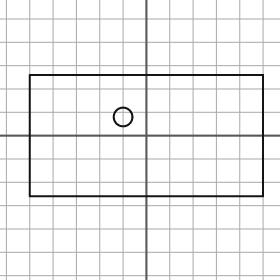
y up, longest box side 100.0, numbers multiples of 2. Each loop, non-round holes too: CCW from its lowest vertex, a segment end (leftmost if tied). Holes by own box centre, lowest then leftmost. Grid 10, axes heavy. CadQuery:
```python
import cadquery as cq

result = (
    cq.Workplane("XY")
    .moveTo(-50.0, -26.0)
    .lineTo(50.0, -26.0)
    .lineTo(50.0, 26.0)
    .lineTo(-50.0, 26.0)
    .close()
    .moveTo(-10.0, 8.0)
    .circle(4.0)
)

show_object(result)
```